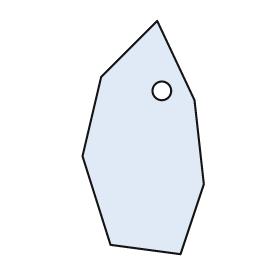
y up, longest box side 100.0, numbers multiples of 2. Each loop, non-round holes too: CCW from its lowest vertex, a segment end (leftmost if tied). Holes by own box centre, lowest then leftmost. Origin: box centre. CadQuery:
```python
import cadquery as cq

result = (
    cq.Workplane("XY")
    .moveTo(16.0, -50.0)
    .lineTo(26.0, -20.0)
    .lineTo(22.0, 16.0)
    .lineTo(6.0, 50.0)
    .lineTo(-18.0, 26.0)
    .lineTo(-26.0, -8.0)
    .lineTo(-14.0, -46.0)
    .close()
    .moveTo(8.0, 20.0)
    .circle(4.0)
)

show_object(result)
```